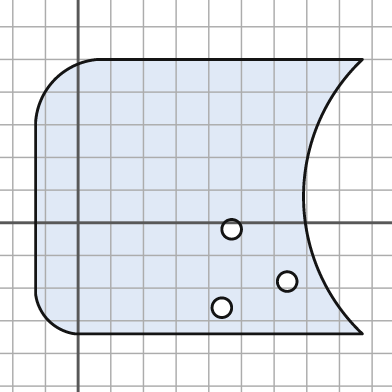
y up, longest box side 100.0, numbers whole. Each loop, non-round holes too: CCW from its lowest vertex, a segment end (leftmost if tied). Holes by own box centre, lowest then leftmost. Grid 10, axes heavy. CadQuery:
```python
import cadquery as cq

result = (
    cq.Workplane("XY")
    .moveTo(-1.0, -34.0)
    .lineTo(87.0, -34.0)
    .threePointArc((69.0, 8.0), (87.0, 50.0))
    .lineTo(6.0, 50.0)
    .threePointArc((-7.0, 44.0), (-13.0, 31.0))
    .lineTo(-13.0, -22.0)
    .threePointArc((-9.0, -30.0), (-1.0, -34.0))
    .close()
    .moveTo(44.0, -26.0)
    .circle(3.0)
    .moveTo(64.0, -18.0)
    .circle(3.0)
    .moveTo(47.0, -2.0)
    .circle(3.0)
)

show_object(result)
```